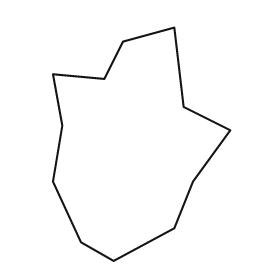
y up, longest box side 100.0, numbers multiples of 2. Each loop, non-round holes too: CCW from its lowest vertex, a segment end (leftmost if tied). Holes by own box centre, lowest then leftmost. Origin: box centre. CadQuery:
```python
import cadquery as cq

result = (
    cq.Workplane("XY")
    .moveTo(-12.0, -50.0)
    .lineTo(14.0, -36.0)
    .lineTo(22.0, -16.0)
    .lineTo(38.0, 6.0)
    .lineTo(18.0, 16.0)
    .lineTo(14.0, 50.0)
    .lineTo(-8.0, 44.0)
    .lineTo(-16.0, 28.0)
    .lineTo(-38.0, 30.0)
    .lineTo(-34.0, 8.0)
    .lineTo(-38.0, -16.0)
    .lineTo(-26.0, -42.0)
    .close()
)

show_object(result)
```